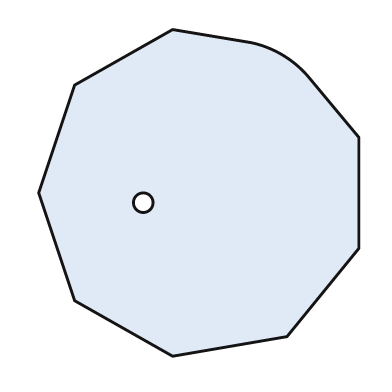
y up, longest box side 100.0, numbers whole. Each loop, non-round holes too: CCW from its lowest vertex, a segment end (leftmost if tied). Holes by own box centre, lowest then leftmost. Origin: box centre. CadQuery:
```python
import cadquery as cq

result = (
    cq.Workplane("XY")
    .moveTo(-8.0, -50.0)
    .lineTo(27.0, -44.0)
    .lineTo(49.0, -17.0)
    .lineTo(49.0, 17.0)
    .lineTo(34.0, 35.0)
    .threePointArc((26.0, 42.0), (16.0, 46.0))
    .lineTo(-8.0, 50.0)
    .lineTo(-38.0, 33.0)
    .lineTo(-49.0, 0.0)
    .lineTo(-38.0, -33.0)
    .close()
    .moveTo(-17.0, -3.0)
    .circle(3.0)
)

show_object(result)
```